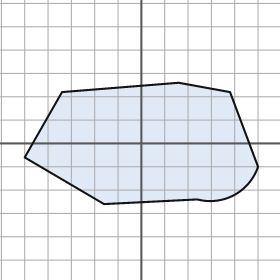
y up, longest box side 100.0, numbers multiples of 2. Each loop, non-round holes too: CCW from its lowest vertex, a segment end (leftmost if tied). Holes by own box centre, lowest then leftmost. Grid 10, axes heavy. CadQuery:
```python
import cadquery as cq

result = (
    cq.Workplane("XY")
    .moveTo(-16.0, -26.0)
    .lineTo(24.0, -24.0)
    .threePointArc((40.0, -22.0), (50.0, -10.0))
    .lineTo(38.0, 22.0)
    .lineTo(16.0, 26.0)
    .lineTo(-34.0, 22.0)
    .lineTo(-50.0, -6.0)
    .close()
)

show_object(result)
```